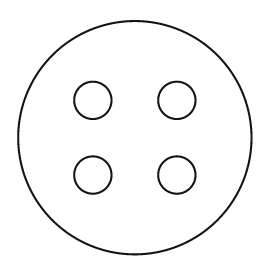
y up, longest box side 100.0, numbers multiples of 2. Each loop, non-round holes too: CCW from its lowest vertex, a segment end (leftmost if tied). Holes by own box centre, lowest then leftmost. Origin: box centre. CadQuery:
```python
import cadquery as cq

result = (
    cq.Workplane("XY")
    .moveTo(0.0, 0.0)
    .circle(50.0)
    .moveTo(-18.0, -16.0)
    .circle(8.0)
    .moveTo(18.0, -16.0)
    .circle(8.0)
    .moveTo(-18.0, 16.0)
    .circle(8.0)
    .moveTo(18.0, 16.0)
    .circle(8.0)
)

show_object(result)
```